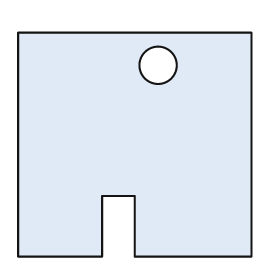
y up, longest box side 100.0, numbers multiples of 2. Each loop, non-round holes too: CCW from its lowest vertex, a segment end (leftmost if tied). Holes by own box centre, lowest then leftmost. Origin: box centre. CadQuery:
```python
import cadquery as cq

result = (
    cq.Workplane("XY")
    .moveTo(-50.0, -48.0)
    .lineTo(-14.0, -48.0)
    .lineTo(-14.0, -22.0)
    .lineTo(0.0, -22.0)
    .lineTo(0.0, -48.0)
    .lineTo(50.0, -48.0)
    .lineTo(50.0, 48.0)
    .lineTo(-50.0, 48.0)
    .close()
    .moveTo(10.0, 34.0)
    .circle(8.0)
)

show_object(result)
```